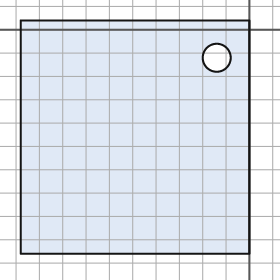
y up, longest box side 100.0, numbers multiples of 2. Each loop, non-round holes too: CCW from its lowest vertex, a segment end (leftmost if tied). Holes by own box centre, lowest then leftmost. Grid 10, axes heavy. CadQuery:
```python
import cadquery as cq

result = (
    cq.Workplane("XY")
    .moveTo(-98.0, -96.0)
    .lineTo(0.0, -96.0)
    .lineTo(0.0, 4.0)
    .lineTo(-98.0, 4.0)
    .close()
    .moveTo(-14.0, -12.0)
    .circle(6.0)
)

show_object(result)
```